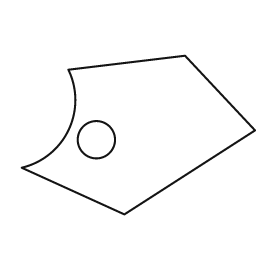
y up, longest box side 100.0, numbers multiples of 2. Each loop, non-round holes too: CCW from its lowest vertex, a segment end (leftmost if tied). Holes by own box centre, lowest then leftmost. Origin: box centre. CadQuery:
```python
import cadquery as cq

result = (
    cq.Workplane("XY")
    .moveTo(-6.0, -34.0)
    .lineTo(50.0, 2.0)
    .lineTo(20.0, 34.0)
    .lineTo(-30.0, 28.0)
    .threePointArc((-30.0, 2.0), (-50.0, -14.0))
    .close()
    .moveTo(-18.0, -2.0)
    .circle(8.0)
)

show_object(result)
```